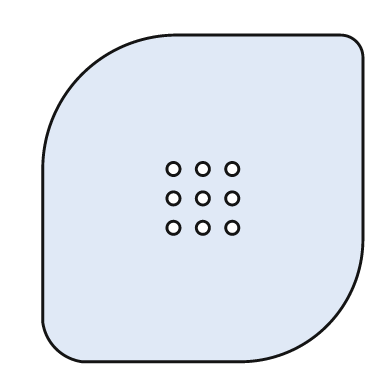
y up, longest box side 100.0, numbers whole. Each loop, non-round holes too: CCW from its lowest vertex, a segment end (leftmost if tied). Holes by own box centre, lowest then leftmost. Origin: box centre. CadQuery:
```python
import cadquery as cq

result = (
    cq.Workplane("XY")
    .moveTo(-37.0, -50.0)
    .lineTo(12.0, -50.0)
    .threePointArc((38.0, -39.0), (49.0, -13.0))
    .lineTo(49.0, 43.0)
    .threePointArc((47.0, 48.0), (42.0, 50.0))
    .lineTo(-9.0, 50.0)
    .threePointArc((-37.0, 38.0), (-49.0, 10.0))
    .lineTo(-49.0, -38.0)
    .threePointArc((-45.0, -46.0), (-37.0, -50.0))
    .close()
    .moveTo(-9.0, -9.0)
    .circle(2.0)
    .moveTo(0.0, -9.0)
    .circle(2.0)
    .moveTo(9.0, -9.0)
    .circle(2.0)
    .moveTo(-9.0, 0.0)
    .circle(2.0)
    .moveTo(0.0, 0.0)
    .circle(2.0)
    .moveTo(9.0, 0.0)
    .circle(2.0)
    .moveTo(-9.0, 9.0)
    .circle(2.0)
    .moveTo(0.0, 9.0)
    .circle(2.0)
    .moveTo(9.0, 9.0)
    .circle(2.0)
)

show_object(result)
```